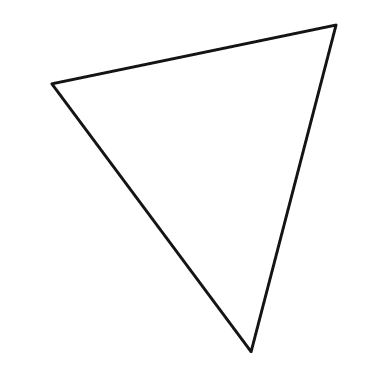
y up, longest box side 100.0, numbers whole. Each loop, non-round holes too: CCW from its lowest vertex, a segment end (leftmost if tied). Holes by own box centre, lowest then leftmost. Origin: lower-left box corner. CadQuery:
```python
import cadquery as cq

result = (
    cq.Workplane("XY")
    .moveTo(61.0, 0.0)
    .lineTo(87.0, 100.0)
    .lineTo(0.0, 82.0)
    .close()
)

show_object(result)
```